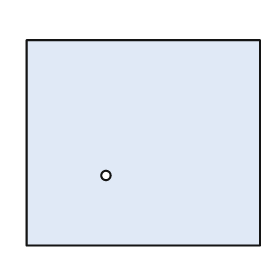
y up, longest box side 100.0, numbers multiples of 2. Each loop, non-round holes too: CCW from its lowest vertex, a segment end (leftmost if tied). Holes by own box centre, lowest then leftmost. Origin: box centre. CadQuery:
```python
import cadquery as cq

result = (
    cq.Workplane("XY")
    .moveTo(-50.0, -44.0)
    .lineTo(50.0, -44.0)
    .lineTo(50.0, 44.0)
    .lineTo(-50.0, 44.0)
    .close()
    .moveTo(-16.0, -14.0)
    .circle(2.0)
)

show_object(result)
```